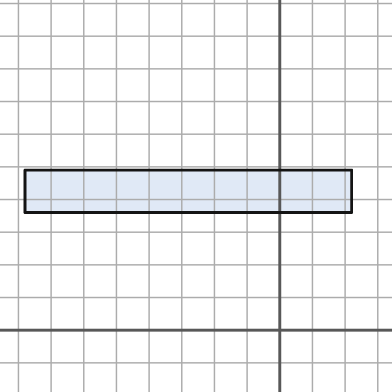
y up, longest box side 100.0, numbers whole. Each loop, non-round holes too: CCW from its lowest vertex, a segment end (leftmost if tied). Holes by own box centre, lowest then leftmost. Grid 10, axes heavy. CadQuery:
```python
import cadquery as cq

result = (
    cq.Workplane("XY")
    .moveTo(-78.0, 36.0)
    .lineTo(22.0, 36.0)
    .lineTo(22.0, 49.0)
    .lineTo(-78.0, 49.0)
    .close()
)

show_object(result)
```